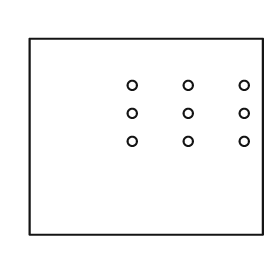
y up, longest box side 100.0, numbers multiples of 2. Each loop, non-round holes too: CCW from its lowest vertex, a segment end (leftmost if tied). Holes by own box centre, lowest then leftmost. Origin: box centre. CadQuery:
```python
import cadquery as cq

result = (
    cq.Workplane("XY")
    .moveTo(-50.0, -42.0)
    .lineTo(50.0, -42.0)
    .lineTo(50.0, 42.0)
    .lineTo(-50.0, 42.0)
    .close()
    .moveTo(-6.0, -2.0)
    .circle(2.0)
    .moveTo(18.0, -2.0)
    .circle(2.0)
    .moveTo(42.0, -2.0)
    .circle(2.0)
    .moveTo(-6.0, 10.0)
    .circle(2.0)
    .moveTo(18.0, 10.0)
    .circle(2.0)
    .moveTo(42.0, 10.0)
    .circle(2.0)
    .moveTo(-6.0, 22.0)
    .circle(2.0)
    .moveTo(18.0, 22.0)
    .circle(2.0)
    .moveTo(42.0, 22.0)
    .circle(2.0)
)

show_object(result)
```